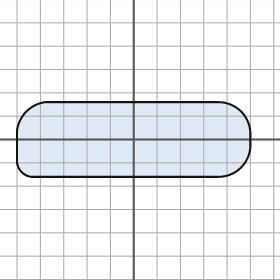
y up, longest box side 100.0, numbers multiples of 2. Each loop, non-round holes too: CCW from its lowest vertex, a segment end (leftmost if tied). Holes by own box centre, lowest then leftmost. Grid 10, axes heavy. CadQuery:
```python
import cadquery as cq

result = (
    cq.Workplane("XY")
    .moveTo(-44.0, -16.0)
    .lineTo(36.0, -16.0)
    .threePointArc((46.0, -12.0), (50.0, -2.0))
    .lineTo(50.0, 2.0)
    .threePointArc((46.0, 12.0), (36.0, 16.0))
    .lineTo(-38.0, 16.0)
    .threePointArc((-46.0, 12.0), (-50.0, 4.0))
    .lineTo(-50.0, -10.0)
    .threePointArc((-48.0, -14.0), (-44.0, -16.0))
    .close()
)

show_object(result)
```